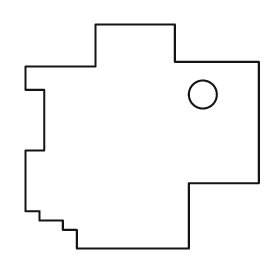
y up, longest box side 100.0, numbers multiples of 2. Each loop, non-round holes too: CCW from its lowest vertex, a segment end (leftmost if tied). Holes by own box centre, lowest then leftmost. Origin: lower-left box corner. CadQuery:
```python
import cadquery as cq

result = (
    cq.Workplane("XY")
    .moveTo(22.0, 0.0)
    .lineTo(70.0, 0.0)
    .lineTo(70.0, 28.0)
    .lineTo(100.0, 28.0)
    .lineTo(100.0, 80.0)
    .lineTo(64.0, 80.0)
    .lineTo(64.0, 96.0)
    .lineTo(30.0, 96.0)
    .lineTo(30.0, 78.0)
    .lineTo(0.0, 78.0)
    .lineTo(0.0, 68.0)
    .lineTo(8.0, 68.0)
    .lineTo(8.0, 42.0)
    .lineTo(0.0, 42.0)
    .lineTo(0.0, 16.0)
    .lineTo(6.0, 16.0)
    .lineTo(6.0, 12.0)
    .lineTo(16.0, 12.0)
    .lineTo(16.0, 8.0)
    .lineTo(22.0, 8.0)
    .close()
    .moveTo(76.0, 66.0)
    .circle(6.0)
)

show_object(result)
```